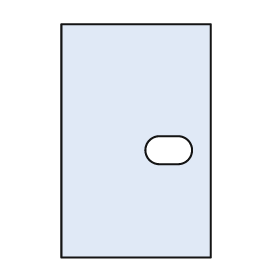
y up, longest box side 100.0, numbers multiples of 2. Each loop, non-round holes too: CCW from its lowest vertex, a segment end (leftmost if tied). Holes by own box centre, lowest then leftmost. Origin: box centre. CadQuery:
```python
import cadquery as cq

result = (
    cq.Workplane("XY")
    .moveTo(-32.0, -50.0)
    .lineTo(32.0, -50.0)
    .lineTo(32.0, 50.0)
    .lineTo(-32.0, 50.0)
    .close()
    .moveTo(10.0, -10.0)
    .lineTo(18.0, -10.0)
    .threePointArc((24.0, -4.0), (18.0, 2.0))
    .lineTo(10.0, 2.0)
    .threePointArc((4.0, -4.0), (10.0, -10.0))
    .close()
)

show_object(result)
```